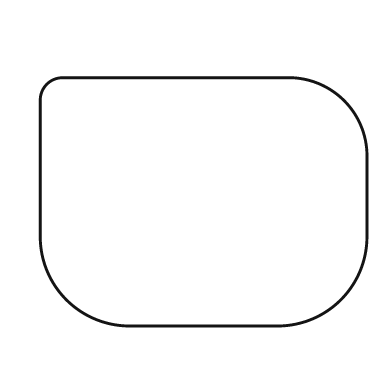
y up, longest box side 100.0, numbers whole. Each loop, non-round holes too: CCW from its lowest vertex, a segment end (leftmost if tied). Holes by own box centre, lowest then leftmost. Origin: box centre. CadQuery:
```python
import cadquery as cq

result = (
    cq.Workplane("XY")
    .moveTo(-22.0, -38.0)
    .lineTo(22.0, -38.0)
    .threePointArc((42.0, -30.0), (50.0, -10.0))
    .lineTo(50.0, 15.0)
    .threePointArc((43.0, 31.0), (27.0, 38.0))
    .lineTo(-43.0, 38.0)
    .threePointArc((-48.0, 36.0), (-50.0, 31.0))
    .lineTo(-50.0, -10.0)
    .threePointArc((-42.0, -30.0), (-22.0, -38.0))
    .close()
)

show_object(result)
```